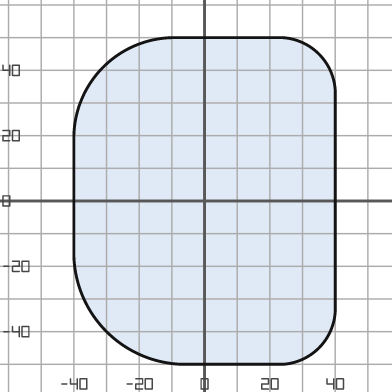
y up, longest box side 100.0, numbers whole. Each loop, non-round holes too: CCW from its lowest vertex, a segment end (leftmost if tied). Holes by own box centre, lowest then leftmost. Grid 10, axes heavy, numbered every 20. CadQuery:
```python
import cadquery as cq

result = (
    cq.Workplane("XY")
    .moveTo(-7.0, -50.0)
    .lineTo(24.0, -50.0)
    .threePointArc((35.0, -45.0), (40.0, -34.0))
    .lineTo(40.0, 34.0)
    .threePointArc((35.0, 45.0), (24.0, 50.0))
    .lineTo(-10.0, 50.0)
    .threePointArc((-31.0, 41.0), (-40.0, 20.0))
    .lineTo(-40.0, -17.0)
    .threePointArc((-30.0, -40.0), (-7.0, -50.0))
    .close()
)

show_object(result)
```